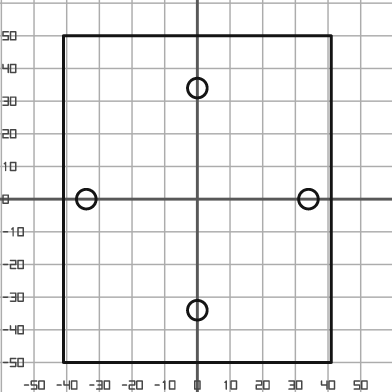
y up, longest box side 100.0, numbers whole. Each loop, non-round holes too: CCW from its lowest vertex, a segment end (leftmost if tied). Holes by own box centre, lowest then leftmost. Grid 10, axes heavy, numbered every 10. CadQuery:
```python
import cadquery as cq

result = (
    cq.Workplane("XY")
    .moveTo(-41.0, -50.0)
    .lineTo(41.0, -50.0)
    .lineTo(41.0, 50.0)
    .lineTo(-41.0, 50.0)
    .close()
    .moveTo(0.0, -34.0)
    .circle(3.0)
    .moveTo(-34.0, 0.0)
    .circle(3.0)
    .moveTo(34.0, 0.0)
    .circle(3.0)
    .moveTo(0.0, 34.0)
    .circle(3.0)
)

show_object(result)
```